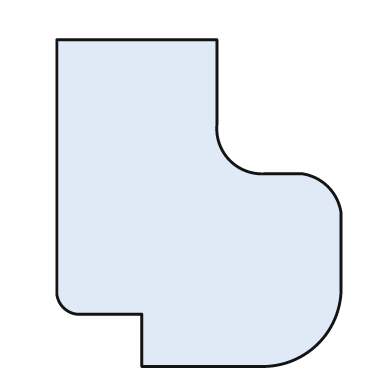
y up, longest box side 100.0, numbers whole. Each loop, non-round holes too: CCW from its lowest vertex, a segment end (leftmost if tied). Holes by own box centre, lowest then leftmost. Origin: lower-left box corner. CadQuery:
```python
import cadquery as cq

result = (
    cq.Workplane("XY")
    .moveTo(26.0, 0.0)
    .lineTo(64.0, 0.0)
    .threePointArc((80.0, 7.0), (87.0, 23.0))
    .lineTo(87.0, 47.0)
    .threePointArc((83.0, 55.0), (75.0, 59.0))
    .lineTo(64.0, 59.0)
    .threePointArc((53.0, 63.0), (49.0, 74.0))
    .lineTo(49.0, 100.0)
    .lineTo(0.0, 100.0)
    .lineTo(0.0, 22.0)
    .threePointArc((2.0, 18.0), (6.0, 16.0))
    .lineTo(26.0, 16.0)
    .close()
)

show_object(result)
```